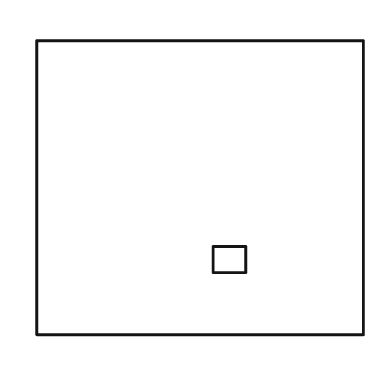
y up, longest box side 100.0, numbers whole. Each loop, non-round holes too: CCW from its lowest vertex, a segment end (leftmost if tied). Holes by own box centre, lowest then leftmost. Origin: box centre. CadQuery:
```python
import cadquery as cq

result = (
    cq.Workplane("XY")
    .moveTo(-50.0, -45.0)
    .lineTo(50.0, -45.0)
    .lineTo(50.0, 45.0)
    .lineTo(-50.0, 45.0)
    .close()
    .moveTo(4.0, -26.0)
    .lineTo(14.0, -26.0)
    .lineTo(14.0, -18.0)
    .lineTo(4.0, -18.0)
    .close()
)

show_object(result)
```